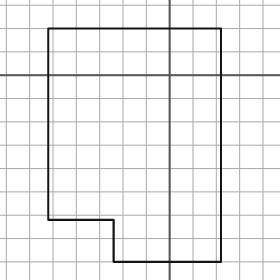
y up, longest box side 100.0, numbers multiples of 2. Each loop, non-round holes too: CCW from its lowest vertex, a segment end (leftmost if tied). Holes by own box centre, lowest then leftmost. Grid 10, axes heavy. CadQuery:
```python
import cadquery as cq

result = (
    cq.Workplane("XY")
    .moveTo(-24.0, -80.0)
    .lineTo(22.0, -80.0)
    .lineTo(22.0, 20.0)
    .lineTo(-52.0, 20.0)
    .lineTo(-52.0, -62.0)
    .lineTo(-24.0, -62.0)
    .close()
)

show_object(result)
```